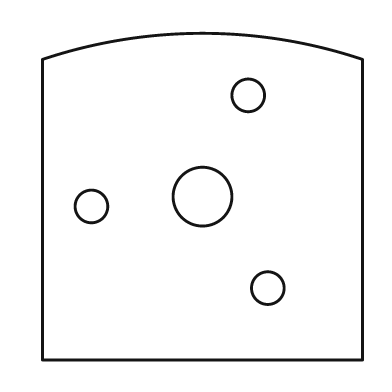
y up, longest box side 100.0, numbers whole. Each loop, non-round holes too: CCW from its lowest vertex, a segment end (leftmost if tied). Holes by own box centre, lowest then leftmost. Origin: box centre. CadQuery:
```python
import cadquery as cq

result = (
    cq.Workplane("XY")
    .moveTo(-49.0, -50.0)
    .lineTo(49.0, -50.0)
    .lineTo(49.0, 42.0)
    .threePointArc((0.0, 50.0), (-49.0, 42.0))
    .close()
    .moveTo(20.0, -28.0)
    .circle(5.0)
    .moveTo(-34.0, -3.0)
    .circle(5.0)
    .moveTo(0.0, 0.0)
    .circle(9.0)
    .moveTo(14.0, 31.0)
    .circle(5.0)
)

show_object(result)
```